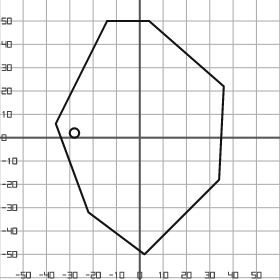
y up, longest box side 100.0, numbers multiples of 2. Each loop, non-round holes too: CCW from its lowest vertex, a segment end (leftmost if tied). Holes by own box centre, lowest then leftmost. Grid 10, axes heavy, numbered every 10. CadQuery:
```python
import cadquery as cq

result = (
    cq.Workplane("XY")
    .moveTo(2.0, -50.0)
    .lineTo(34.0, -18.0)
    .lineTo(36.0, 22.0)
    .lineTo(4.0, 50.0)
    .lineTo(-14.0, 50.0)
    .lineTo(-36.0, 6.0)
    .lineTo(-22.0, -32.0)
    .close()
    .moveTo(-28.0, 2.0)
    .circle(2.0)
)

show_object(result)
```